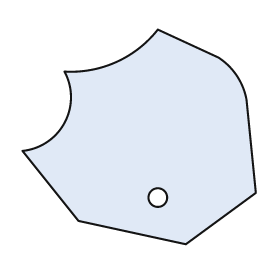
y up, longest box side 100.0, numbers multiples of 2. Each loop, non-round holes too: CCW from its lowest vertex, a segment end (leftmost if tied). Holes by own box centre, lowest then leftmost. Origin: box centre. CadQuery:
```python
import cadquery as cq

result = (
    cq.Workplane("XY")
    .moveTo(20.0, -46.0)
    .lineTo(50.0, -24.0)
    .lineTo(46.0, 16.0)
    .threePointArc((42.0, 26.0), (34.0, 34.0))
    .lineTo(8.0, 46.0)
    .threePointArc((-10.0, 32.0), (-32.0, 28.0))
    .threePointArc((-32.0, 6.0), (-50.0, -6.0))
    .lineTo(-26.0, -36.0)
    .close()
    .moveTo(8.0, -26.0)
    .circle(4.0)
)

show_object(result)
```